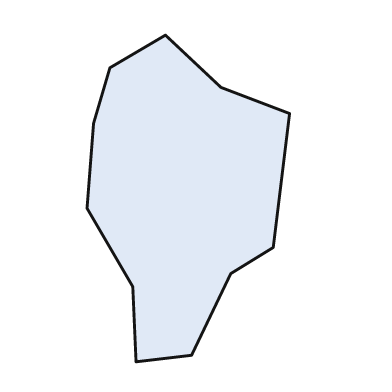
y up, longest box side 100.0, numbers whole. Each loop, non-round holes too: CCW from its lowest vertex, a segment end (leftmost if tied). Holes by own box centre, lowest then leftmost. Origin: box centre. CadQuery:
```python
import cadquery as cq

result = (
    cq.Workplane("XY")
    .moveTo(-16.0, -50.0)
    .lineTo(1.0, -48.0)
    .lineTo(13.0, -23.0)
    .lineTo(26.0, -15.0)
    .lineTo(31.0, 26.0)
    .lineTo(10.0, 34.0)
    .lineTo(-7.0, 50.0)
    .lineTo(-24.0, 40.0)
    .lineTo(-29.0, 23.0)
    .lineTo(-31.0, -3.0)
    .lineTo(-17.0, -27.0)
    .close()
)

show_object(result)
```